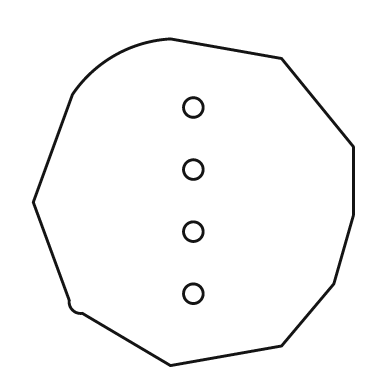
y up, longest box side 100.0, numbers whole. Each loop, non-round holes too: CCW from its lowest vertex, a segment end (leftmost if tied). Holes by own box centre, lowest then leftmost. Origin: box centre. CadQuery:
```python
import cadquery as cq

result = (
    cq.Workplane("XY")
    .moveTo(-7.0, -50.0)
    .lineTo(27.0, -44.0)
    .lineTo(43.0, -25.0)
    .lineTo(49.0, -4.0)
    .lineTo(49.0, 17.0)
    .lineTo(27.0, 44.0)
    .lineTo(-7.0, 50.0)
    .threePointArc((-24.0, 45.0), (-37.0, 33.0))
    .lineTo(-49.0, 0.0)
    .lineTo(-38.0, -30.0)
    .threePointArc((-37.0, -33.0), (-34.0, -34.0))
    .close()
    .moveTo(0.0, -28.0)
    .circle(3.0)
    .moveTo(0.0, -9.0)
    .circle(3.0)
    .moveTo(0.0, 10.0)
    .circle(3.0)
    .moveTo(0.0, 29.0)
    .circle(3.0)
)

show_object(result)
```